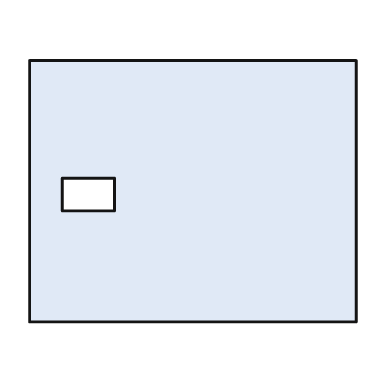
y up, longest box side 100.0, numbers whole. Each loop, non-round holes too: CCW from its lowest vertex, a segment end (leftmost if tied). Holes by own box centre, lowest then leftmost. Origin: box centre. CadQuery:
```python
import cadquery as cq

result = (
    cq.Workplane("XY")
    .moveTo(-50.0, -40.0)
    .lineTo(50.0, -40.0)
    .lineTo(50.0, 40.0)
    .lineTo(-50.0, 40.0)
    .close()
    .moveTo(-40.0, -6.0)
    .lineTo(-24.0, -6.0)
    .lineTo(-24.0, 4.0)
    .lineTo(-40.0, 4.0)
    .close()
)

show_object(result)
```